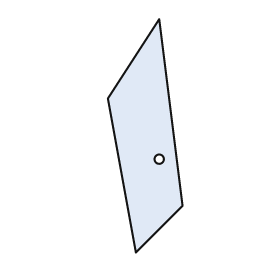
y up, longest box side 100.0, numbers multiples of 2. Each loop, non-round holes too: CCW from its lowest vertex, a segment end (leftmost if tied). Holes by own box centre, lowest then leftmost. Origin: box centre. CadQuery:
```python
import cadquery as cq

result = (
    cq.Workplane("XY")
    .moveTo(-4.0, -50.0)
    .lineTo(16.0, -30.0)
    .lineTo(6.0, 50.0)
    .lineTo(-16.0, 16.0)
    .close()
    .moveTo(6.0, -10.0)
    .circle(2.0)
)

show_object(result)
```